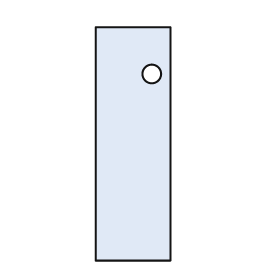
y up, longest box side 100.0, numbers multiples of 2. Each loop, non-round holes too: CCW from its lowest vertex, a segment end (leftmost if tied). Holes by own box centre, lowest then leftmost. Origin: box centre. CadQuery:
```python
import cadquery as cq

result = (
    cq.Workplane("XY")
    .moveTo(-16.0, -50.0)
    .lineTo(16.0, -50.0)
    .lineTo(16.0, 50.0)
    .lineTo(-16.0, 50.0)
    .close()
    .moveTo(8.0, 30.0)
    .circle(4.0)
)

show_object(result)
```